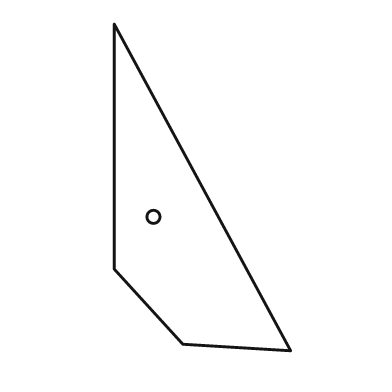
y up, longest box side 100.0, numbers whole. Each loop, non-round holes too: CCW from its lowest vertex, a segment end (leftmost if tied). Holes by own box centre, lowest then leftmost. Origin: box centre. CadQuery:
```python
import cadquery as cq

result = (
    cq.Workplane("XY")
    .moveTo(27.0, -50.0)
    .lineTo(-27.0, 50.0)
    .lineTo(-27.0, -25.0)
    .lineTo(-6.0, -48.0)
    .close()
    .moveTo(-15.0, -9.0)
    .circle(2.0)
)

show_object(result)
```